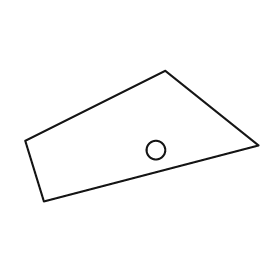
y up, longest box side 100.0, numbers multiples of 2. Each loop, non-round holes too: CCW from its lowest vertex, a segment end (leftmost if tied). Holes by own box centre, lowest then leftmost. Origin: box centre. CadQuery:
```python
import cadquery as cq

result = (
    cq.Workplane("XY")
    .moveTo(-42.0, -28.0)
    .lineTo(50.0, -4.0)
    .lineTo(10.0, 28.0)
    .lineTo(-50.0, -2.0)
    .close()
    .moveTo(6.0, -6.0)
    .circle(4.0)
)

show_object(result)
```